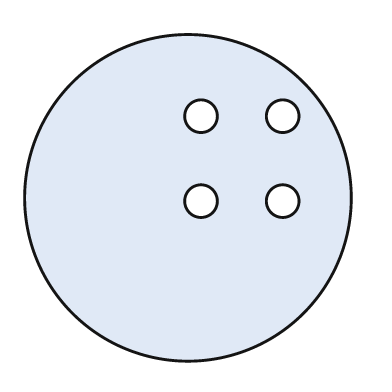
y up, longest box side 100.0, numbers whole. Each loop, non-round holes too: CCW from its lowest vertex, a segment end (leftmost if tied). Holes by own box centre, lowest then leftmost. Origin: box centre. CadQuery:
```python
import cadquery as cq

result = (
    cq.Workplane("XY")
    .moveTo(0.0, 0.0)
    .circle(50.0)
    .moveTo(4.0, -1.0)
    .circle(5.0)
    .moveTo(29.0, -1.0)
    .circle(5.0)
    .moveTo(4.0, 25.0)
    .circle(5.0)
    .moveTo(29.0, 25.0)
    .circle(5.0)
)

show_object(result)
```